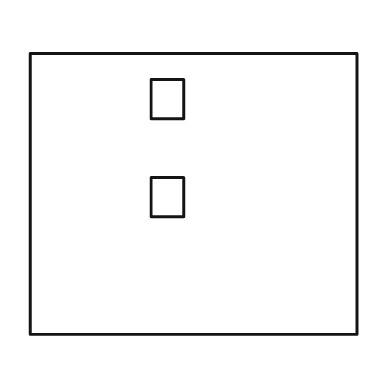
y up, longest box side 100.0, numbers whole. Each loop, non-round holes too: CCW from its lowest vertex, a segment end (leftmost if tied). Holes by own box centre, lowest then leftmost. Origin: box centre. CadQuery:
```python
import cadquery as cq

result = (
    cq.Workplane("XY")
    .moveTo(-50.0, -43.0)
    .lineTo(50.0, -43.0)
    .lineTo(50.0, 43.0)
    .lineTo(-50.0, 43.0)
    .close()
    .moveTo(-13.0, -7.0)
    .lineTo(-3.0, -7.0)
    .lineTo(-3.0, 5.0)
    .lineTo(-13.0, 5.0)
    .close()
    .moveTo(-13.0, 23.0)
    .lineTo(-3.0, 23.0)
    .lineTo(-3.0, 35.0)
    .lineTo(-13.0, 35.0)
    .close()
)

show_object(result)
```